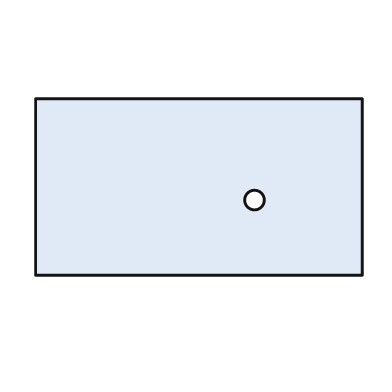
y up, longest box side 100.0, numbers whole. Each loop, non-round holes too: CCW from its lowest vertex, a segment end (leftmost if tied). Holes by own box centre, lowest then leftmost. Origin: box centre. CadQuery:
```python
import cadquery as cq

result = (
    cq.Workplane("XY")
    .moveTo(-50.0, -27.0)
    .lineTo(50.0, -27.0)
    .lineTo(50.0, 27.0)
    .lineTo(-50.0, 27.0)
    .close()
    .moveTo(17.0, -4.0)
    .circle(3.0)
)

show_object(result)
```